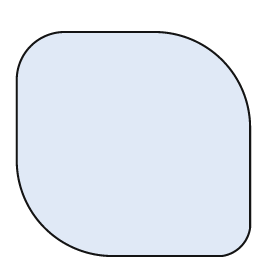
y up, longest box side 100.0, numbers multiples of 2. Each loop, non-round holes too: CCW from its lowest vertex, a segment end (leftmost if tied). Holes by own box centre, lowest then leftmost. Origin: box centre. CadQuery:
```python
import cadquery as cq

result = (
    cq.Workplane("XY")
    .moveTo(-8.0, -48.0)
    .lineTo(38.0, -48.0)
    .threePointArc((46.0, -44.0), (50.0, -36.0))
    .lineTo(50.0, 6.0)
    .threePointArc((38.0, 36.0), (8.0, 48.0))
    .lineTo(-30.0, 48.0)
    .threePointArc((-44.0, 42.0), (-50.0, 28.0))
    .lineTo(-50.0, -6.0)
    .threePointArc((-38.0, -36.0), (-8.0, -48.0))
    .close()
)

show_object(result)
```